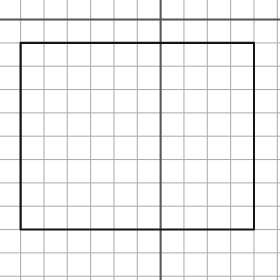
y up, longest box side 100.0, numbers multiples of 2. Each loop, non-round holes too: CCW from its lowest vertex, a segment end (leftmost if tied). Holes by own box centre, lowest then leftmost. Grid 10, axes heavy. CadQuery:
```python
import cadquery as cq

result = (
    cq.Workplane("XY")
    .moveTo(-60.0, -90.0)
    .lineTo(40.0, -90.0)
    .lineTo(40.0, -10.0)
    .lineTo(-60.0, -10.0)
    .close()
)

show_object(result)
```